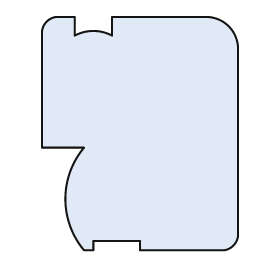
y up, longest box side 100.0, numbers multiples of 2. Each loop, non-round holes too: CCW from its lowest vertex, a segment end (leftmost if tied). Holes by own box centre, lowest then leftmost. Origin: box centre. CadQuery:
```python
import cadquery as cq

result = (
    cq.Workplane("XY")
    .moveTo(-24.0, -50.0)
    .lineTo(-20.0, -50.0)
    .lineTo(-20.0, -46.0)
    .lineTo(0.0, -46.0)
    .lineTo(0.0, -50.0)
    .lineTo(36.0, -50.0)
    .threePointArc((40.0, -48.0), (42.0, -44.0))
    .lineTo(42.0, 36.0)
    .threePointArc((38.0, 46.0), (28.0, 50.0))
    .lineTo(-12.0, 50.0)
    .lineTo(-12.0, 42.0)
    .threePointArc((-20.0, 44.0), (-28.0, 42.0))
    .lineTo(-28.0, 50.0)
    .lineTo(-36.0, 50.0)
    .threePointArc((-40.0, 48.0), (-42.0, 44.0))
    .lineTo(-42.0, -6.0)
    .lineTo(-24.0, -6.0)
    .threePointArc((-32.0, -28.0), (-24.0, -50.0))
    .close()
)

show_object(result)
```